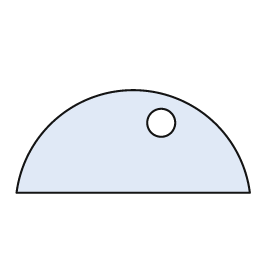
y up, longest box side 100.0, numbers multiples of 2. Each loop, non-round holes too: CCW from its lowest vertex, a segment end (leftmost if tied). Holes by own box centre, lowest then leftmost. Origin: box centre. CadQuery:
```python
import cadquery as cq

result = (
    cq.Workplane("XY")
    .moveTo(-50.0, -22.0)
    .lineTo(50.0, -22.0)
    .threePointArc((0.0, 22.0), (-50.0, -22.0))
    .close()
    .moveTo(12.0, 8.0)
    .circle(6.0)
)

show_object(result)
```